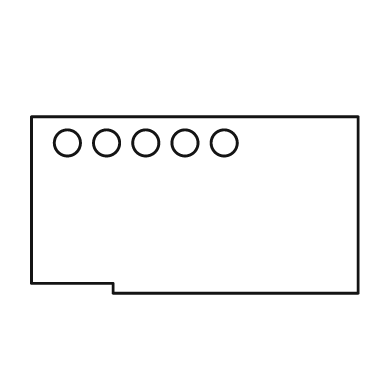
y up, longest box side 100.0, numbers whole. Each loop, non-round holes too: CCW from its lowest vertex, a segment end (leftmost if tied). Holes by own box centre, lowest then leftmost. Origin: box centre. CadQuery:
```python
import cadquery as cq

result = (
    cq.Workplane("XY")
    .moveTo(-25.0, -27.0)
    .lineTo(50.0, -27.0)
    .lineTo(50.0, 27.0)
    .lineTo(-50.0, 27.0)
    .lineTo(-50.0, -24.0)
    .lineTo(-25.0, -24.0)
    .close()
    .moveTo(-39.0, 19.0)
    .circle(4.0)
    .moveTo(-27.0, 19.0)
    .circle(4.0)
    .moveTo(-15.0, 19.0)
    .circle(4.0)
    .moveTo(-3.0, 19.0)
    .circle(4.0)
    .moveTo(9.0, 19.0)
    .circle(4.0)
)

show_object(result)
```